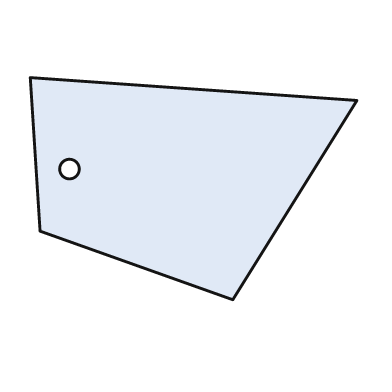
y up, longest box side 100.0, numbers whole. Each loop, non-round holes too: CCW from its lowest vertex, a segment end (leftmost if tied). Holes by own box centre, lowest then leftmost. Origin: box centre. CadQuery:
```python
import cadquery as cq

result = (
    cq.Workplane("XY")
    .moveTo(12.0, -34.0)
    .lineTo(50.0, 27.0)
    .lineTo(-50.0, 34.0)
    .lineTo(-47.0, -13.0)
    .close()
    .moveTo(-38.0, 6.0)
    .circle(3.0)
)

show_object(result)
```